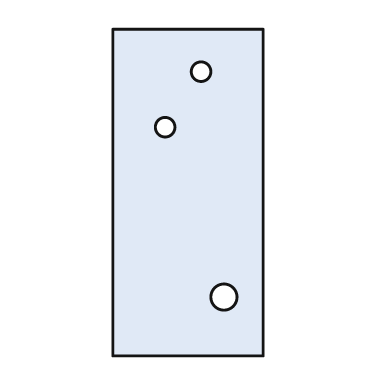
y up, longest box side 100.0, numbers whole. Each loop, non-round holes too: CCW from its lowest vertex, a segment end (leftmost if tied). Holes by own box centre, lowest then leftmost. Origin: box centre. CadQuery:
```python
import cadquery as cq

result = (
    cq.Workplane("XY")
    .moveTo(-23.0, -50.0)
    .lineTo(23.0, -50.0)
    .lineTo(23.0, 50.0)
    .lineTo(-23.0, 50.0)
    .close()
    .moveTo(11.0, -32.0)
    .circle(4.0)
    .moveTo(-7.0, 20.0)
    .circle(3.0)
    .moveTo(4.0, 37.0)
    .circle(3.0)
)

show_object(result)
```